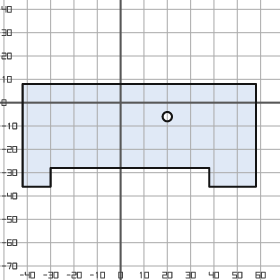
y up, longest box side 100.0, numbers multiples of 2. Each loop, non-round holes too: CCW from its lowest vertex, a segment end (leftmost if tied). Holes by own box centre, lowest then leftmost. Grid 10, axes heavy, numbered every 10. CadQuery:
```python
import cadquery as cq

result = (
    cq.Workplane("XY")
    .moveTo(-42.0, -36.0)
    .lineTo(-30.0, -36.0)
    .lineTo(-30.0, -28.0)
    .lineTo(38.0, -28.0)
    .lineTo(38.0, -36.0)
    .lineTo(58.0, -36.0)
    .lineTo(58.0, 8.0)
    .lineTo(-42.0, 8.0)
    .close()
    .moveTo(20.0, -6.0)
    .circle(2.0)
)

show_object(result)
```